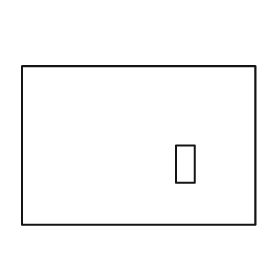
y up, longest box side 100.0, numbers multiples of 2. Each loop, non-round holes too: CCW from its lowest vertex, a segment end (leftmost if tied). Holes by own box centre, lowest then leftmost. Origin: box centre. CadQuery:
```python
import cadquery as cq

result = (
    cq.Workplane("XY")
    .moveTo(-50.0, -34.0)
    .lineTo(50.0, -34.0)
    .lineTo(50.0, 34.0)
    .lineTo(-50.0, 34.0)
    .close()
    .moveTo(16.0, -16.0)
    .lineTo(24.0, -16.0)
    .lineTo(24.0, 0.0)
    .lineTo(16.0, 0.0)
    .close()
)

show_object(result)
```